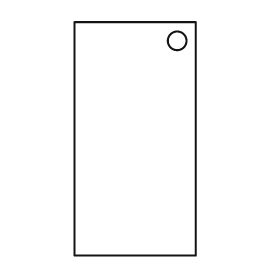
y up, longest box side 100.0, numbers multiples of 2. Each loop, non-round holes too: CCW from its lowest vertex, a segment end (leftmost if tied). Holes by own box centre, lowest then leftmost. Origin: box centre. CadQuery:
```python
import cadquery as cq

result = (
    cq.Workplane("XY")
    .moveTo(-26.0, -50.0)
    .lineTo(26.0, -50.0)
    .lineTo(26.0, 50.0)
    .lineTo(-26.0, 50.0)
    .close()
    .moveTo(18.0, 42.0)
    .circle(4.0)
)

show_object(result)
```